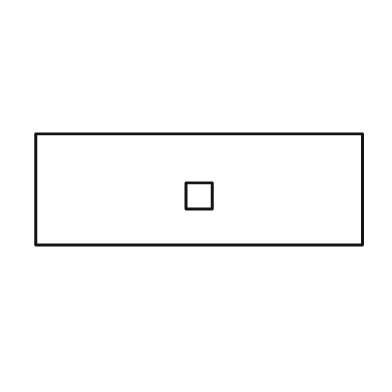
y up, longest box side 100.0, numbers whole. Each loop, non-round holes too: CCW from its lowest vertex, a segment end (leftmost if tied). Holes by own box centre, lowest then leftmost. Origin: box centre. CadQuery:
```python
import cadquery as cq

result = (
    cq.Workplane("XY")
    .moveTo(-50.0, -17.0)
    .lineTo(50.0, -17.0)
    .lineTo(50.0, 17.0)
    .lineTo(-50.0, 17.0)
    .close()
    .moveTo(-4.0, -6.0)
    .lineTo(4.0, -6.0)
    .lineTo(4.0, 2.0)
    .lineTo(-4.0, 2.0)
    .close()
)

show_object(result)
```